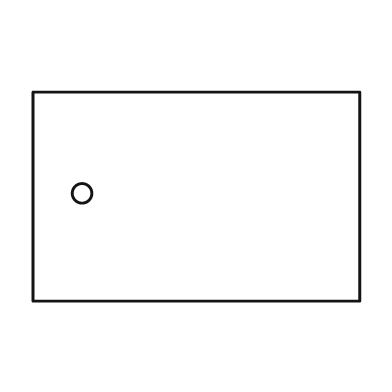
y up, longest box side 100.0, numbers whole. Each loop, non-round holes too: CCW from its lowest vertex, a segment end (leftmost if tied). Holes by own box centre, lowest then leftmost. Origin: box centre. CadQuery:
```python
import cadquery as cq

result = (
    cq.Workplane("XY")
    .moveTo(-50.0, -32.0)
    .lineTo(50.0, -32.0)
    .lineTo(50.0, 32.0)
    .lineTo(-50.0, 32.0)
    .close()
    .moveTo(-35.0, 1.0)
    .circle(3.0)
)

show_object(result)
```